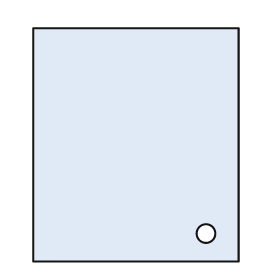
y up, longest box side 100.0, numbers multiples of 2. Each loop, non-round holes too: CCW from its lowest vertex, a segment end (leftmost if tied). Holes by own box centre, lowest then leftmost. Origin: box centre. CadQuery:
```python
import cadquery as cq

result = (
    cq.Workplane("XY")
    .moveTo(-44.0, -50.0)
    .lineTo(44.0, -50.0)
    .lineTo(44.0, 50.0)
    .lineTo(-44.0, 50.0)
    .close()
    .moveTo(30.0, -38.0)
    .circle(4.0)
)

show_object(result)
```